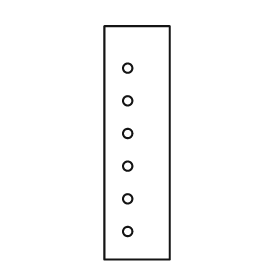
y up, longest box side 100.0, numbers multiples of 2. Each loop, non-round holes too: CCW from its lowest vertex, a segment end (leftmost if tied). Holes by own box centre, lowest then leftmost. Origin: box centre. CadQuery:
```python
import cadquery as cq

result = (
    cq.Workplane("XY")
    .moveTo(-14.0, -50.0)
    .lineTo(14.0, -50.0)
    .lineTo(14.0, 50.0)
    .lineTo(-14.0, 50.0)
    .close()
    .moveTo(-4.0, -38.0)
    .circle(2.0)
    .moveTo(-4.0, -24.0)
    .circle(2.0)
    .moveTo(-4.0, -10.0)
    .circle(2.0)
    .moveTo(-4.0, 4.0)
    .circle(2.0)
    .moveTo(-4.0, 18.0)
    .circle(2.0)
    .moveTo(-4.0, 32.0)
    .circle(2.0)
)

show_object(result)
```